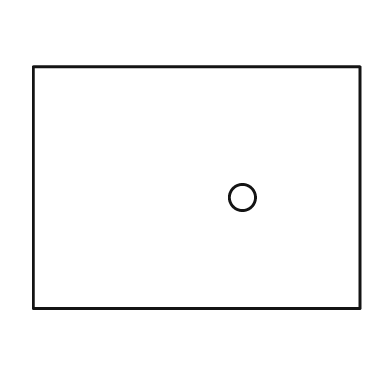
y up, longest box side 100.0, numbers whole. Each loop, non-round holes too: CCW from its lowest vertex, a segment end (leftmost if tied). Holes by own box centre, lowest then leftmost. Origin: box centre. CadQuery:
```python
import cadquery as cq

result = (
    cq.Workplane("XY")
    .moveTo(-50.0, -37.0)
    .lineTo(50.0, -37.0)
    .lineTo(50.0, 37.0)
    .lineTo(-50.0, 37.0)
    .close()
    .moveTo(14.0, -3.0)
    .circle(4.0)
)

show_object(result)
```